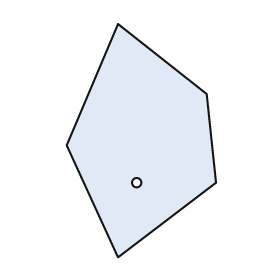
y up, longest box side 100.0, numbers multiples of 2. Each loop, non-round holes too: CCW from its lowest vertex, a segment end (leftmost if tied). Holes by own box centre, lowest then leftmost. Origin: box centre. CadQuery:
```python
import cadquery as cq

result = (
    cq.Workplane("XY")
    .moveTo(-10.0, -50.0)
    .lineTo(32.0, -18.0)
    .lineTo(28.0, 20.0)
    .lineTo(-10.0, 50.0)
    .lineTo(-32.0, -2.0)
    .close()
    .moveTo(-2.0, -18.0)
    .circle(2.0)
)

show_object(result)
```